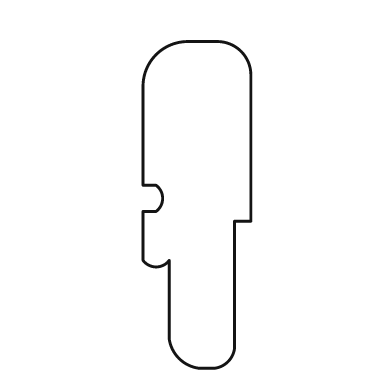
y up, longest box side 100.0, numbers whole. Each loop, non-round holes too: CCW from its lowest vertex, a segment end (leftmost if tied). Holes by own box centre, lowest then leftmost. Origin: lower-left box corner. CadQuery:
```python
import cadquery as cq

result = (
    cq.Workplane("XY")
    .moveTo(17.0, 0.0)
    .lineTo(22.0, 0.0)
    .threePointArc((26.0, 2.0), (28.0, 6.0))
    .lineTo(28.0, 45.0)
    .lineTo(33.0, 45.0)
    .lineTo(33.0, 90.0)
    .threePointArc((30.0, 97.0), (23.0, 100.0))
    .lineTo(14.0, 100.0)
    .threePointArc((4.0, 96.0), (0.0, 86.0))
    .lineTo(0.0, 56.0)
    .lineTo(4.0, 56.0)
    .threePointArc((6.0, 52.0), (4.0, 48.0))
    .lineTo(0.0, 48.0)
    .lineTo(0.0, 33.0)
    .threePointArc((4.0, 31.0), (8.0, 33.0))
    .lineTo(8.0, 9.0)
    .threePointArc((11.0, 3.0), (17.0, 0.0))
    .close()
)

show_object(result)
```